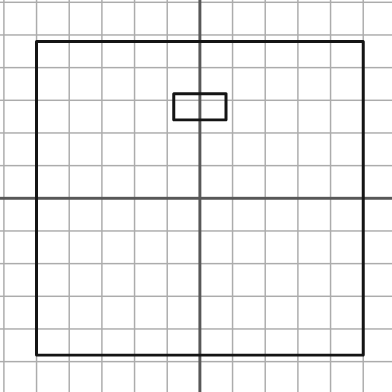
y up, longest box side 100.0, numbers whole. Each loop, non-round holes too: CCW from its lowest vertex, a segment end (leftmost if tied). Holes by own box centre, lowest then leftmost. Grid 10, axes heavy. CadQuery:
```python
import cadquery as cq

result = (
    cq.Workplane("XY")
    .moveTo(-50.0, -48.0)
    .lineTo(50.0, -48.0)
    .lineTo(50.0, 48.0)
    .lineTo(-50.0, 48.0)
    .close()
    .moveTo(-8.0, 24.0)
    .lineTo(8.0, 24.0)
    .lineTo(8.0, 32.0)
    .lineTo(-8.0, 32.0)
    .close()
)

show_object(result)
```